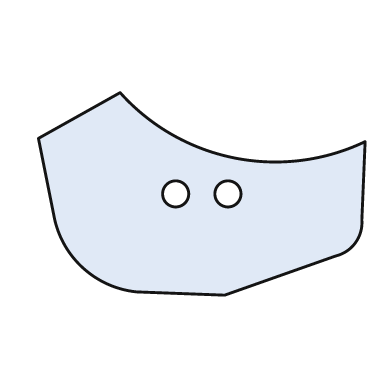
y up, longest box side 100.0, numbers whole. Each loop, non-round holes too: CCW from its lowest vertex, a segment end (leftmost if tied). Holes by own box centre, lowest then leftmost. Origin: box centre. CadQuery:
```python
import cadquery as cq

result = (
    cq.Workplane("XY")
    .moveTo(7.0, -31.0)
    .lineTo(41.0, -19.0)
    .threePointArc((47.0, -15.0), (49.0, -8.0))
    .lineTo(50.0, 16.0)
    .threePointArc((10.0, 11.0), (-25.0, 31.0))
    .lineTo(-50.0, 17.0)
    .lineTo(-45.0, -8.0)
    .threePointArc((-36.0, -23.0), (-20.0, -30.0))
    .close()
    .moveTo(-8.0, 0.0)
    .circle(4.0)
    .moveTo(8.0, 0.0)
    .circle(4.0)
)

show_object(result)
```